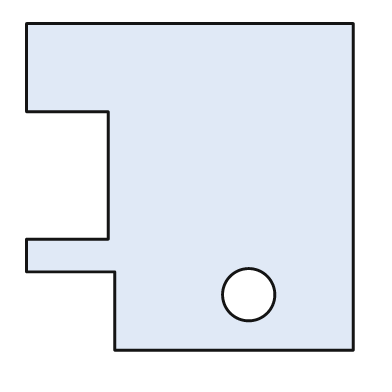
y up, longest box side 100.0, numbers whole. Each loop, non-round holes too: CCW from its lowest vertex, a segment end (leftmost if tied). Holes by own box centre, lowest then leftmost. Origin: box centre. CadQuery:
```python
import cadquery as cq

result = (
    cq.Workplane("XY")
    .moveTo(-23.0, -50.0)
    .lineTo(50.0, -50.0)
    .lineTo(50.0, 50.0)
    .lineTo(-50.0, 50.0)
    .lineTo(-50.0, 23.0)
    .lineTo(-25.0, 23.0)
    .lineTo(-25.0, -16.0)
    .lineTo(-50.0, -16.0)
    .lineTo(-50.0, -26.0)
    .lineTo(-23.0, -26.0)
    .close()
    .moveTo(18.0, -33.0)
    .circle(8.0)
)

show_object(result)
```